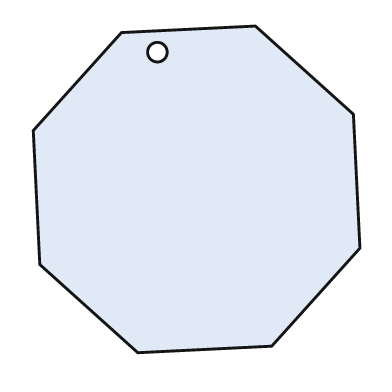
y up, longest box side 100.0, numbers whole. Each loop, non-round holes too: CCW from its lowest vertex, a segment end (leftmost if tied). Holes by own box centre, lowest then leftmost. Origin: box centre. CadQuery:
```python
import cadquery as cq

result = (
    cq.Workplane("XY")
    .moveTo(-18.0, -50.0)
    .lineTo(23.0, -48.0)
    .lineTo(50.0, -18.0)
    .lineTo(48.0, 23.0)
    .lineTo(18.0, 50.0)
    .lineTo(-23.0, 48.0)
    .lineTo(-50.0, 18.0)
    .lineTo(-48.0, -23.0)
    .close()
    .moveTo(-12.0, 42.0)
    .circle(3.0)
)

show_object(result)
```